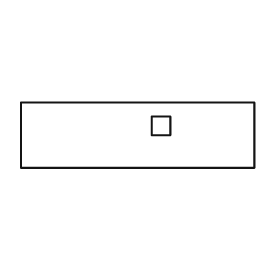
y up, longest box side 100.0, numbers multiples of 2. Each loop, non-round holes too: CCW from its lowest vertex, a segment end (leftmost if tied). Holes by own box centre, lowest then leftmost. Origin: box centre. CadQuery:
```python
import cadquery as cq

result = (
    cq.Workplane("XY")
    .moveTo(-50.0, -14.0)
    .lineTo(50.0, -14.0)
    .lineTo(50.0, 14.0)
    .lineTo(-50.0, 14.0)
    .close()
    .moveTo(6.0, 0.0)
    .lineTo(14.0, 0.0)
    .lineTo(14.0, 8.0)
    .lineTo(6.0, 8.0)
    .close()
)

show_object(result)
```